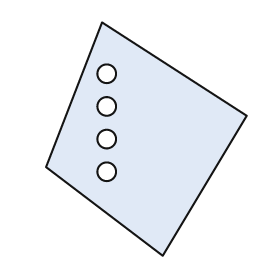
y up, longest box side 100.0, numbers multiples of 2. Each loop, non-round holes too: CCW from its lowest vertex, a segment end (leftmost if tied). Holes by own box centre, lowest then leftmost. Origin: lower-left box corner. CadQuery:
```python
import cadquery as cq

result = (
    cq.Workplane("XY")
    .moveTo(50.0, 0.0)
    .lineTo(86.0, 60.0)
    .lineTo(24.0, 100.0)
    .lineTo(0.0, 38.0)
    .close()
    .moveTo(26.0, 36.0)
    .circle(4.0)
    .moveTo(26.0, 50.0)
    .circle(4.0)
    .moveTo(26.0, 64.0)
    .circle(4.0)
    .moveTo(26.0, 78.0)
    .circle(4.0)
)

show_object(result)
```